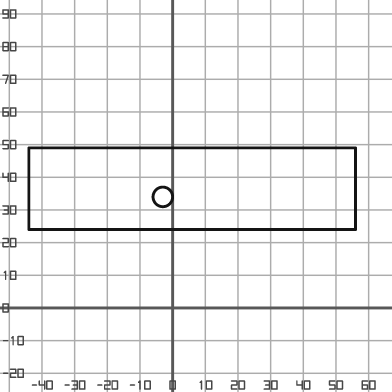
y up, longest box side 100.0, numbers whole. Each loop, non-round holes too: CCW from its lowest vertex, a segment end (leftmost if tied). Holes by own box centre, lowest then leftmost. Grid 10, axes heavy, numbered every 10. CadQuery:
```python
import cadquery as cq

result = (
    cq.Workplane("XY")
    .moveTo(-44.0, 24.0)
    .lineTo(56.0, 24.0)
    .lineTo(56.0, 49.0)
    .lineTo(-44.0, 49.0)
    .close()
    .moveTo(-3.0, 34.0)
    .circle(3.0)
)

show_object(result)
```